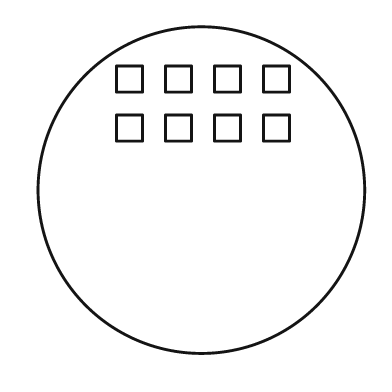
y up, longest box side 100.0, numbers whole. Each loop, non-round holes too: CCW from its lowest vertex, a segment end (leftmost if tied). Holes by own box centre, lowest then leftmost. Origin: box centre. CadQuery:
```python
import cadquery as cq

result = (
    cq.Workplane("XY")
    .moveTo(0.0, 0.0)
    .circle(50.0)
    .moveTo(-26.0, 15.0)
    .lineTo(-18.0, 15.0)
    .lineTo(-18.0, 23.0)
    .lineTo(-26.0, 23.0)
    .close()
    .moveTo(-11.0, 15.0)
    .lineTo(-3.0, 15.0)
    .lineTo(-3.0, 23.0)
    .lineTo(-11.0, 23.0)
    .close()
    .moveTo(4.0, 15.0)
    .lineTo(12.0, 15.0)
    .lineTo(12.0, 23.0)
    .lineTo(4.0, 23.0)
    .close()
    .moveTo(19.0, 15.0)
    .lineTo(27.0, 15.0)
    .lineTo(27.0, 23.0)
    .lineTo(19.0, 23.0)
    .close()
    .moveTo(-26.0, 30.0)
    .lineTo(-18.0, 30.0)
    .lineTo(-18.0, 38.0)
    .lineTo(-26.0, 38.0)
    .close()
    .moveTo(-11.0, 30.0)
    .lineTo(-3.0, 30.0)
    .lineTo(-3.0, 38.0)
    .lineTo(-11.0, 38.0)
    .close()
    .moveTo(4.0, 30.0)
    .lineTo(12.0, 30.0)
    .lineTo(12.0, 38.0)
    .lineTo(4.0, 38.0)
    .close()
    .moveTo(19.0, 30.0)
    .lineTo(27.0, 30.0)
    .lineTo(27.0, 38.0)
    .lineTo(19.0, 38.0)
    .close()
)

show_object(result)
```